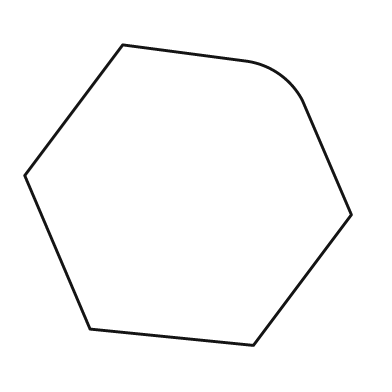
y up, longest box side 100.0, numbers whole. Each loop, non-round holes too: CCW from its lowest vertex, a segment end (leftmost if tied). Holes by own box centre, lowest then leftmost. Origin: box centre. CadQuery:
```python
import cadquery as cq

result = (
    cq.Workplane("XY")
    .moveTo(20.0, -46.0)
    .lineTo(50.0, -6.0)
    .lineTo(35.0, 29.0)
    .threePointArc((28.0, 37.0), (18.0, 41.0))
    .lineTo(-20.0, 46.0)
    .lineTo(-50.0, 6.0)
    .lineTo(-30.0, -41.0)
    .close()
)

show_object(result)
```